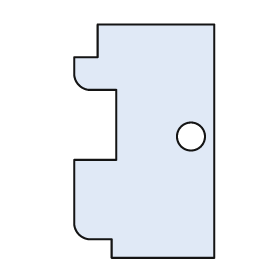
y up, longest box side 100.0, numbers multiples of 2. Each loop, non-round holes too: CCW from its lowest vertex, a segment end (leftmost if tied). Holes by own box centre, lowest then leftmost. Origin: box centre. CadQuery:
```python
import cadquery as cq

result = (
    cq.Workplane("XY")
    .moveTo(-14.0, -50.0)
    .lineTo(30.0, -50.0)
    .lineTo(30.0, 50.0)
    .lineTo(-20.0, 50.0)
    .lineTo(-20.0, 36.0)
    .lineTo(-30.0, 36.0)
    .lineTo(-30.0, 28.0)
    .threePointArc((-28.0, 24.0), (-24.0, 22.0))
    .lineTo(-12.0, 22.0)
    .lineTo(-12.0, -8.0)
    .lineTo(-30.0, -8.0)
    .lineTo(-30.0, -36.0)
    .threePointArc((-28.0, -40.0), (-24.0, -42.0))
    .lineTo(-14.0, -42.0)
    .close()
    .moveTo(20.0, 2.0)
    .circle(6.0)
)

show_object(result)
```